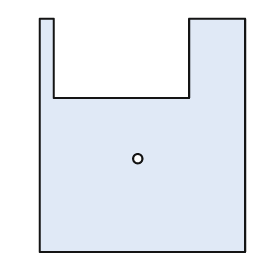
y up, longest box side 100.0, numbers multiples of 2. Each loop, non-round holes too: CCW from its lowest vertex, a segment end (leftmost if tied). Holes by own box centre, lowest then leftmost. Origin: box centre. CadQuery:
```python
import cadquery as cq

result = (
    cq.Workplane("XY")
    .moveTo(-44.0, -50.0)
    .lineTo(44.0, -50.0)
    .lineTo(44.0, 50.0)
    .lineTo(20.0, 50.0)
    .lineTo(20.0, 16.0)
    .lineTo(-38.0, 16.0)
    .lineTo(-38.0, 50.0)
    .lineTo(-44.0, 50.0)
    .close()
    .moveTo(-2.0, -10.0)
    .circle(2.0)
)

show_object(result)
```